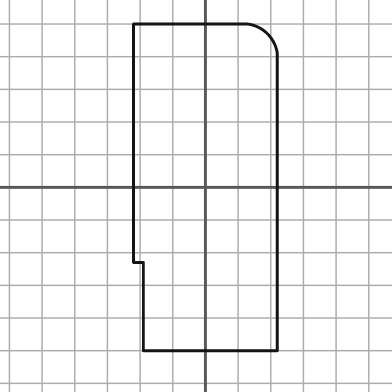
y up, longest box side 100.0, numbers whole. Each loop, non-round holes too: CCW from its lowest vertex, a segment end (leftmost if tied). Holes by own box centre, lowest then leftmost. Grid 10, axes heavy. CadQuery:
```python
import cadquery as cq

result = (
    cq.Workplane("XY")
    .moveTo(-19.0, -50.0)
    .lineTo(22.0, -50.0)
    .lineTo(22.0, 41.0)
    .threePointArc((19.0, 47.0), (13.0, 50.0))
    .lineTo(-22.0, 50.0)
    .lineTo(-22.0, -23.0)
    .lineTo(-19.0, -23.0)
    .close()
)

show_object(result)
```